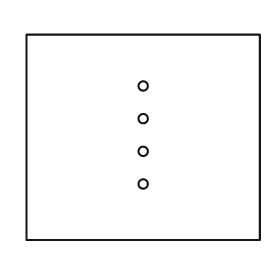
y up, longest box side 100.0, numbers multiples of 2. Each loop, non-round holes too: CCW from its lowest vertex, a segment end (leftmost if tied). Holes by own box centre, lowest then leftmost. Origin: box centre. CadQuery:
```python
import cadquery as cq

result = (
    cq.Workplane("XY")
    .moveTo(-50.0, -44.0)
    .lineTo(50.0, -44.0)
    .lineTo(50.0, 44.0)
    .lineTo(-50.0, 44.0)
    .close()
    .moveTo(0.0, -20.0)
    .circle(2.0)
    .moveTo(0.0, -6.0)
    .circle(2.0)
    .moveTo(0.0, 8.0)
    .circle(2.0)
    .moveTo(0.0, 22.0)
    .circle(2.0)
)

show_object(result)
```